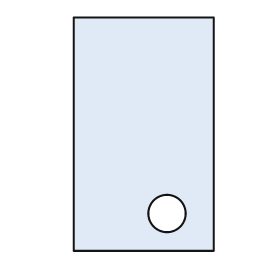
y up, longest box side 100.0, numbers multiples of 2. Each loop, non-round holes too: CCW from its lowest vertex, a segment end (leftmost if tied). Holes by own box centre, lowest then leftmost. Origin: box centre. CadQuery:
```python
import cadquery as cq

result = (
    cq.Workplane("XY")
    .moveTo(-30.0, -50.0)
    .lineTo(30.0, -50.0)
    .lineTo(30.0, 50.0)
    .lineTo(-30.0, 50.0)
    .close()
    .moveTo(10.0, -34.0)
    .circle(8.0)
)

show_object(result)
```